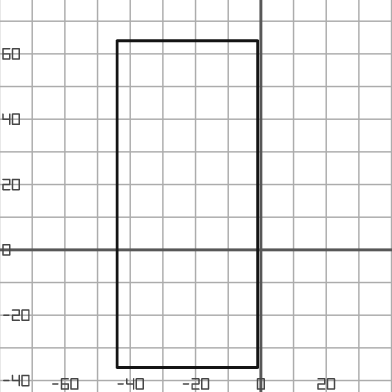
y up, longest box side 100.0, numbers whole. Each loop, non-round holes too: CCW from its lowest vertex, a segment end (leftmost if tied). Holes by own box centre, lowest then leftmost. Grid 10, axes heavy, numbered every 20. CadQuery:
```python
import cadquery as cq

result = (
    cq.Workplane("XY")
    .moveTo(-44.0, -36.0)
    .lineTo(-1.0, -36.0)
    .lineTo(-1.0, 64.0)
    .lineTo(-44.0, 64.0)
    .close()
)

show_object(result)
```